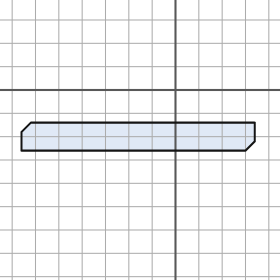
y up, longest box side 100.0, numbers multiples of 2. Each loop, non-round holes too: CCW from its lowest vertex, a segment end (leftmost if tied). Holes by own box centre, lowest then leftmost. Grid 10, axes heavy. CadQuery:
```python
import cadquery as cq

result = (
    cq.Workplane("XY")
    .moveTo(-66.0, -26.0)
    .lineTo(30.0, -26.0)
    .lineTo(34.0, -22.0)
    .lineTo(34.0, -14.0)
    .lineTo(-62.0, -14.0)
    .lineTo(-66.0, -18.0)
    .close()
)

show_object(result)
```